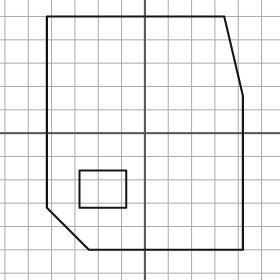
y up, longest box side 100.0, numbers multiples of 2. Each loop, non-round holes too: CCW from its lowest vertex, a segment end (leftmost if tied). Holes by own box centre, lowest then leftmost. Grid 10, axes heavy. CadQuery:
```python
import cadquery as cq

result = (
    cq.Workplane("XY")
    .moveTo(-24.0, -50.0)
    .lineTo(42.0, -50.0)
    .lineTo(42.0, 16.0)
    .lineTo(34.0, 50.0)
    .lineTo(-42.0, 50.0)
    .lineTo(-42.0, -32.0)
    .close()
    .moveTo(-28.0, -32.0)
    .lineTo(-8.0, -32.0)
    .lineTo(-8.0, -16.0)
    .lineTo(-28.0, -16.0)
    .close()
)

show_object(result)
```